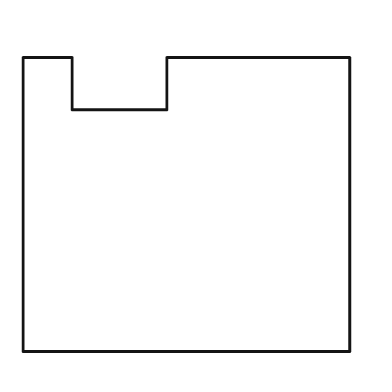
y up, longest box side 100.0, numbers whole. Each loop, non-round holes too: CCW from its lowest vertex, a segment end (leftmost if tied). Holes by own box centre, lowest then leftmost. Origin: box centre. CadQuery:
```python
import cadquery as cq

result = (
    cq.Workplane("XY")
    .moveTo(-50.0, -45.0)
    .lineTo(50.0, -45.0)
    .lineTo(50.0, 45.0)
    .lineTo(-6.0, 45.0)
    .lineTo(-6.0, 29.0)
    .lineTo(-35.0, 29.0)
    .lineTo(-35.0, 45.0)
    .lineTo(-50.0, 45.0)
    .close()
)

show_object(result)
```